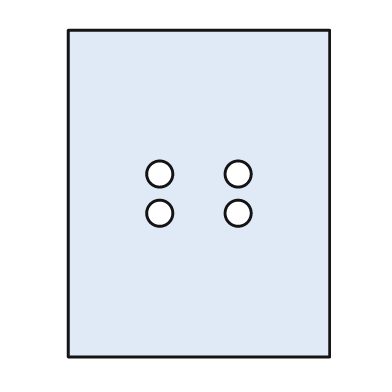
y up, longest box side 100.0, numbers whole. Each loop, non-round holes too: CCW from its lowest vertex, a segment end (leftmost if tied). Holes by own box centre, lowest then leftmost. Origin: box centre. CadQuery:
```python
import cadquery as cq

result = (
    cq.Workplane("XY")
    .moveTo(-40.0, -50.0)
    .lineTo(40.0, -50.0)
    .lineTo(40.0, 50.0)
    .lineTo(-40.0, 50.0)
    .close()
    .moveTo(-12.0, -6.0)
    .circle(4.0)
    .moveTo(12.0, -6.0)
    .circle(4.0)
    .moveTo(-12.0, 6.0)
    .circle(4.0)
    .moveTo(12.0, 6.0)
    .circle(4.0)
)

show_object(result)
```